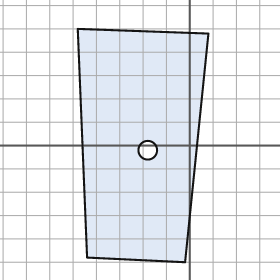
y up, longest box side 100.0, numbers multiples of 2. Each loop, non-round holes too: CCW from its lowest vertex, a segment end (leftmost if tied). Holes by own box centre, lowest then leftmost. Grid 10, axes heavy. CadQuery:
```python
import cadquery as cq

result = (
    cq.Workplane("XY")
    .moveTo(-2.0, -50.0)
    .lineTo(8.0, 48.0)
    .lineTo(-48.0, 50.0)
    .lineTo(-44.0, -48.0)
    .close()
    .moveTo(-18.0, -2.0)
    .circle(4.0)
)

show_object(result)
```